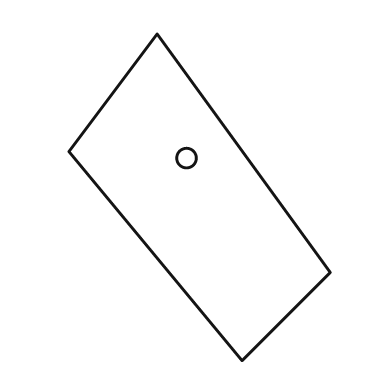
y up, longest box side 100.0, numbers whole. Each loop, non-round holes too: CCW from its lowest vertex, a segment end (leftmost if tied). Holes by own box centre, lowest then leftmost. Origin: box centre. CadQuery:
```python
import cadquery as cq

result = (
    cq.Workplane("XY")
    .moveTo(13.0, -50.0)
    .lineTo(40.0, -23.0)
    .lineTo(-13.0, 50.0)
    .lineTo(-40.0, 14.0)
    .close()
    .moveTo(-4.0, 12.0)
    .circle(3.0)
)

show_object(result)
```